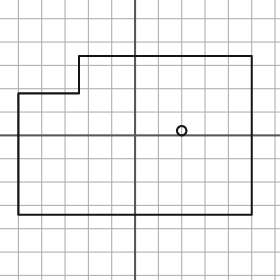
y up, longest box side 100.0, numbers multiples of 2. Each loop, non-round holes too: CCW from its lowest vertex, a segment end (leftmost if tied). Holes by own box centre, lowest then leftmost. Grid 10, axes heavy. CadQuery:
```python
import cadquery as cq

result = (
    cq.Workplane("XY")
    .moveTo(-50.0, -34.0)
    .lineTo(50.0, -34.0)
    .lineTo(50.0, 34.0)
    .lineTo(-24.0, 34.0)
    .lineTo(-24.0, 18.0)
    .lineTo(-50.0, 18.0)
    .close()
    .moveTo(20.0, 2.0)
    .circle(2.0)
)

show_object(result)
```